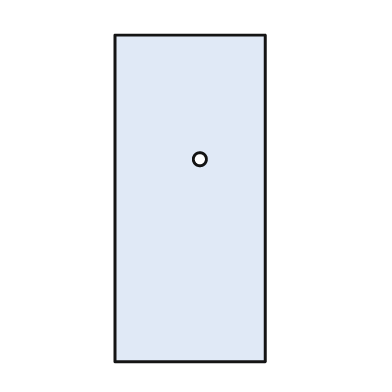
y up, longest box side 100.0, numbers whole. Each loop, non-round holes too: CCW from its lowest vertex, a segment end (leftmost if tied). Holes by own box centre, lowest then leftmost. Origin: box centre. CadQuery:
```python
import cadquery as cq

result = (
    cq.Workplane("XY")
    .moveTo(-23.0, -50.0)
    .lineTo(23.0, -50.0)
    .lineTo(23.0, 50.0)
    .lineTo(-23.0, 50.0)
    .close()
    .moveTo(3.0, 12.0)
    .circle(2.0)
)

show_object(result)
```